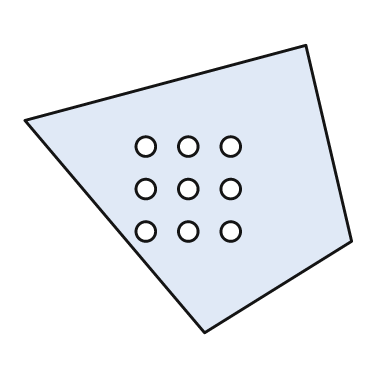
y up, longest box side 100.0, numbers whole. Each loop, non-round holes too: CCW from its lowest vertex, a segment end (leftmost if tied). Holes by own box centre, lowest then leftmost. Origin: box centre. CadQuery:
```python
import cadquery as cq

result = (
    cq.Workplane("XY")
    .moveTo(5.0, -44.0)
    .lineTo(50.0, -16.0)
    .lineTo(36.0, 44.0)
    .lineTo(-50.0, 21.0)
    .close()
    .moveTo(-13.0, -13.0)
    .circle(3.0)
    .moveTo(0.0, -13.0)
    .circle(3.0)
    .moveTo(13.0, -13.0)
    .circle(3.0)
    .moveTo(-13.0, 0.0)
    .circle(3.0)
    .moveTo(0.0, 0.0)
    .circle(3.0)
    .moveTo(13.0, 0.0)
    .circle(3.0)
    .moveTo(-13.0, 13.0)
    .circle(3.0)
    .moveTo(0.0, 13.0)
    .circle(3.0)
    .moveTo(13.0, 13.0)
    .circle(3.0)
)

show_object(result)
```